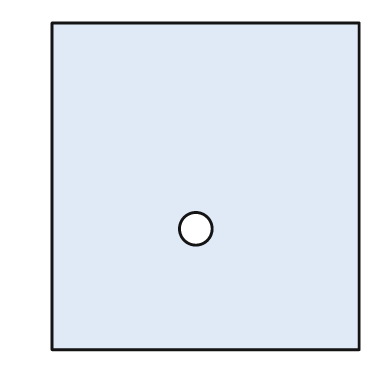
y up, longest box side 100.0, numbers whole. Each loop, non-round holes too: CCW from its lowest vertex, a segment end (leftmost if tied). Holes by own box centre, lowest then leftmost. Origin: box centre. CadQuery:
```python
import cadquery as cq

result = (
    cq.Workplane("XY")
    .moveTo(-47.0, -50.0)
    .lineTo(47.0, -50.0)
    .lineTo(47.0, 50.0)
    .lineTo(-47.0, 50.0)
    .close()
    .moveTo(-3.0, -13.0)
    .circle(5.0)
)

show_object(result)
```